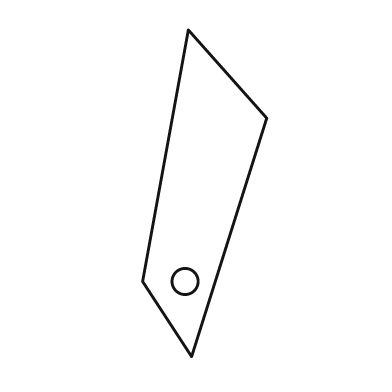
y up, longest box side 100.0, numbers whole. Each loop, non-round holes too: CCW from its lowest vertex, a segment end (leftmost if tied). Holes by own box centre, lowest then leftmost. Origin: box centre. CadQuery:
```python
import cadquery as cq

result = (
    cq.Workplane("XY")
    .moveTo(-4.0, -50.0)
    .lineTo(19.0, 23.0)
    .lineTo(-5.0, 50.0)
    .lineTo(-19.0, -27.0)
    .close()
    .moveTo(-6.0, -27.0)
    .circle(4.0)
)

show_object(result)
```